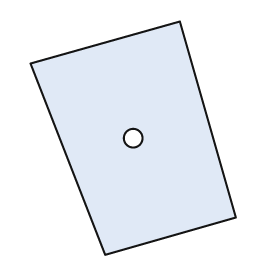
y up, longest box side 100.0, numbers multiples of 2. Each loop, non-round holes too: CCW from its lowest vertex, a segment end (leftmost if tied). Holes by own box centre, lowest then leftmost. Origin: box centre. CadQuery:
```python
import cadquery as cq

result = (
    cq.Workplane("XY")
    .moveTo(-12.0, -50.0)
    .lineTo(44.0, -34.0)
    .lineTo(20.0, 50.0)
    .lineTo(-44.0, 32.0)
    .close()
    .moveTo(0.0, 0.0)
    .circle(4.0)
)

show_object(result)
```